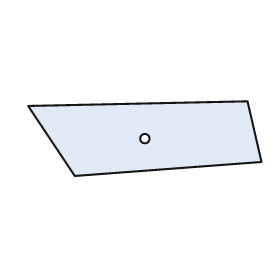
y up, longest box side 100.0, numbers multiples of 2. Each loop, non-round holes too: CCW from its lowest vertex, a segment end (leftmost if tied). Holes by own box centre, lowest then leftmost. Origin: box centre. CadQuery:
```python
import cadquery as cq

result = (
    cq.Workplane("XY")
    .moveTo(-30.0, -16.0)
    .lineTo(50.0, -10.0)
    .lineTo(44.0, 16.0)
    .lineTo(-50.0, 14.0)
    .close()
    .moveTo(0.0, 0.0)
    .circle(2.0)
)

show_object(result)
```